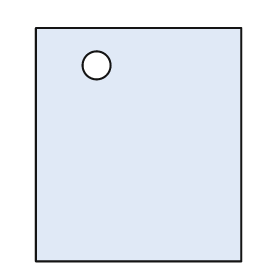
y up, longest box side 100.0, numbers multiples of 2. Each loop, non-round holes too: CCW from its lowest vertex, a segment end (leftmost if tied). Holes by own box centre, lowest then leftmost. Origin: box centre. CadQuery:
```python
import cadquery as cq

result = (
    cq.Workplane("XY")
    .moveTo(-44.0, -50.0)
    .lineTo(44.0, -50.0)
    .lineTo(44.0, 50.0)
    .lineTo(-44.0, 50.0)
    .close()
    .moveTo(-18.0, 34.0)
    .circle(6.0)
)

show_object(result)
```